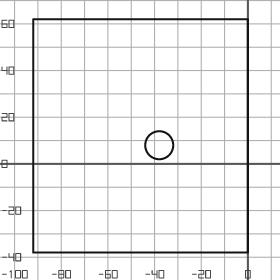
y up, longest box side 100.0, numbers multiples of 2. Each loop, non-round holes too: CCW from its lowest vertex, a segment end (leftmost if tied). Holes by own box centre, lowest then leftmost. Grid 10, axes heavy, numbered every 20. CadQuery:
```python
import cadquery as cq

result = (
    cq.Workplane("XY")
    .moveTo(-92.0, -38.0)
    .lineTo(0.0, -38.0)
    .lineTo(0.0, 62.0)
    .lineTo(-92.0, 62.0)
    .close()
    .moveTo(-38.0, 8.0)
    .circle(6.0)
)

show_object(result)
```